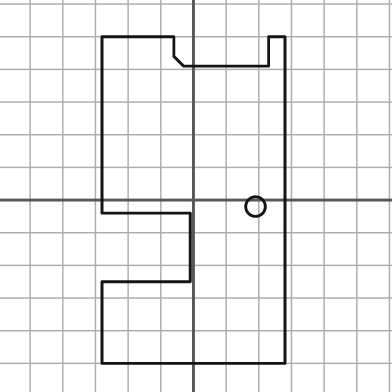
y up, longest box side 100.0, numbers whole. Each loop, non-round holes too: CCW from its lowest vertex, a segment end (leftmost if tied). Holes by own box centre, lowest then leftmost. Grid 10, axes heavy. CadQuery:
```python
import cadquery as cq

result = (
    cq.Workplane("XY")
    .moveTo(-28.0, -50.0)
    .lineTo(28.0, -50.0)
    .lineTo(28.0, 50.0)
    .lineTo(23.0, 50.0)
    .lineTo(23.0, 41.0)
    .lineTo(-3.0, 41.0)
    .lineTo(-6.0, 44.0)
    .lineTo(-6.0, 50.0)
    .lineTo(-28.0, 50.0)
    .lineTo(-28.0, -4.0)
    .lineTo(-1.0, -4.0)
    .lineTo(-1.0, -25.0)
    .lineTo(-28.0, -25.0)
    .close()
    .moveTo(19.0, -2.0)
    .circle(3.0)
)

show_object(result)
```